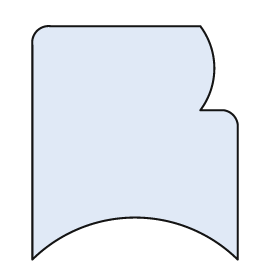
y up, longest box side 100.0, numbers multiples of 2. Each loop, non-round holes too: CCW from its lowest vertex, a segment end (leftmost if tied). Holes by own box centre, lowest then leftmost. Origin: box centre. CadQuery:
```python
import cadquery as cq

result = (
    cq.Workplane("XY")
    .moveTo(-44.0, -50.0)
    .threePointArc((0.0, -32.0), (44.0, -50.0))
    .lineTo(44.0, 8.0)
    .threePointArc((42.0, 12.0), (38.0, 14.0))
    .lineTo(28.0, 14.0)
    .threePointArc((34.0, 32.0), (28.0, 50.0))
    .lineTo(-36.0, 50.0)
    .threePointArc((-42.0, 48.0), (-44.0, 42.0))
    .close()
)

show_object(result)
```